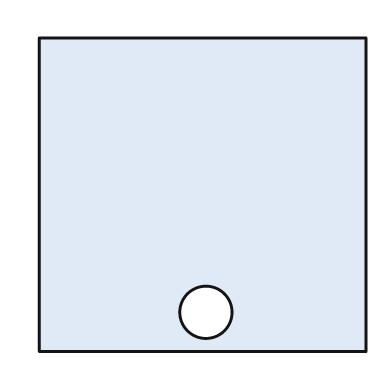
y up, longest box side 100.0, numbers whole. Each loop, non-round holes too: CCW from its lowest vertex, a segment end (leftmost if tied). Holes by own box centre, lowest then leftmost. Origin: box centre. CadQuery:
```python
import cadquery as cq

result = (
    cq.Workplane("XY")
    .moveTo(-50.0, -48.0)
    .lineTo(50.0, -48.0)
    .lineTo(50.0, 48.0)
    .lineTo(-50.0, 48.0)
    .close()
    .moveTo(1.0, -36.0)
    .circle(8.0)
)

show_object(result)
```